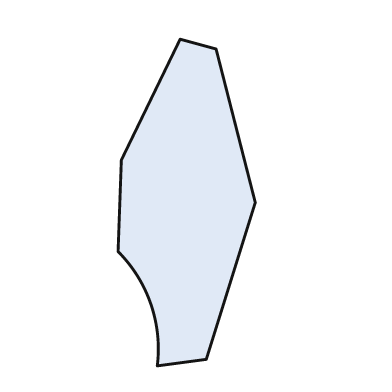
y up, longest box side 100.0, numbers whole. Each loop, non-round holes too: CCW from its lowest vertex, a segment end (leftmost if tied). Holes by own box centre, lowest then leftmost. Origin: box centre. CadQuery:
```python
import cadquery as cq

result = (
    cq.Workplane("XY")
    .moveTo(-9.0, -50.0)
    .lineTo(6.0, -48.0)
    .lineTo(21.0, 0.0)
    .lineTo(9.0, 47.0)
    .lineTo(-2.0, 50.0)
    .lineTo(-20.0, 13.0)
    .lineTo(-21.0, -15.0)
    .threePointArc((-11.0, -31.0), (-9.0, -50.0))
    .close()
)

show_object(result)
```